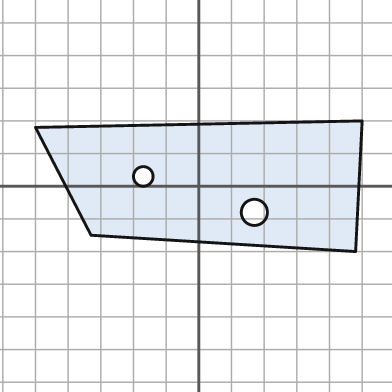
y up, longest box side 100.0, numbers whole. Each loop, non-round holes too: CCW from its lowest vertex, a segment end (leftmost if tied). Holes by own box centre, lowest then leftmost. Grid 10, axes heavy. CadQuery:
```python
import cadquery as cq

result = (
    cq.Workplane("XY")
    .moveTo(48.0, -20.0)
    .lineTo(50.0, 20.0)
    .lineTo(-50.0, 18.0)
    .lineTo(-33.0, -15.0)
    .close()
    .moveTo(17.0, -8.0)
    .circle(4.0)
    .moveTo(-17.0, 3.0)
    .circle(3.0)
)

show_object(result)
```